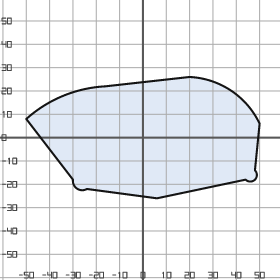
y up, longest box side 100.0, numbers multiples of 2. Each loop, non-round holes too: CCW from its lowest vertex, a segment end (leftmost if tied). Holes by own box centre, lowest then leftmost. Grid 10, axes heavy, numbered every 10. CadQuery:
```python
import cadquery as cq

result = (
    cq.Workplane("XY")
    .moveTo(6.0, -26.0)
    .lineTo(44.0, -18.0)
    .threePointArc((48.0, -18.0), (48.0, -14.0))
    .lineTo(50.0, 6.0)
    .threePointArc((38.0, 20.0), (20.0, 26.0))
    .lineTo(-16.0, 22.0)
    .threePointArc((-34.0, 18.0), (-50.0, 8.0))
    .lineTo(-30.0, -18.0)
    .threePointArc((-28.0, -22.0), (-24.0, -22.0))
    .close()
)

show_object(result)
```